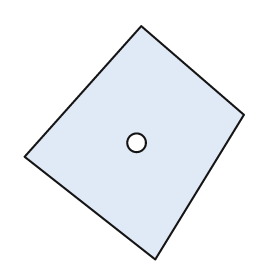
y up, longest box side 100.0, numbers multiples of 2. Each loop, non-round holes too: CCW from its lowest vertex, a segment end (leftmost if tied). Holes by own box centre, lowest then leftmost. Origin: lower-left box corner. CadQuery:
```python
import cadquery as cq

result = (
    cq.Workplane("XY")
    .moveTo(56.0, 0.0)
    .lineTo(94.0, 62.0)
    .lineTo(50.0, 100.0)
    .lineTo(0.0, 44.0)
    .close()
    .moveTo(48.0, 50.0)
    .circle(4.0)
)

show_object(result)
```